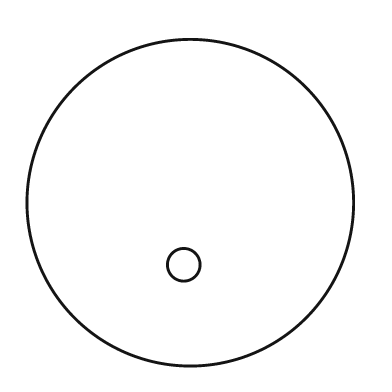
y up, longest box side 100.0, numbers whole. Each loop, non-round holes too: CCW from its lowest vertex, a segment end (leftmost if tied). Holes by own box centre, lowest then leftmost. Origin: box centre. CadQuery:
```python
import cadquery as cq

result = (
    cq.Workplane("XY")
    .moveTo(0.0, 0.0)
    .circle(50.0)
    .moveTo(-2.0, -19.0)
    .circle(5.0)
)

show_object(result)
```